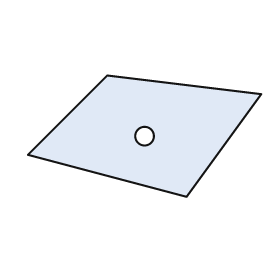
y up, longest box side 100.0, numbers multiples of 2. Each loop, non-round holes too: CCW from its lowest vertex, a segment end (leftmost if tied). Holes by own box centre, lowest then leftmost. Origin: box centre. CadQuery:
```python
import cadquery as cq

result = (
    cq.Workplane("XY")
    .moveTo(18.0, -26.0)
    .lineTo(50.0, 18.0)
    .lineTo(-16.0, 26.0)
    .lineTo(-50.0, -8.0)
    .close()
    .moveTo(0.0, 0.0)
    .circle(4.0)
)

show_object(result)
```